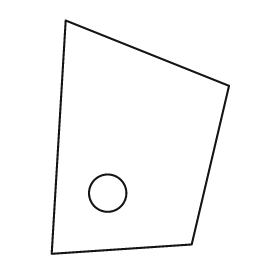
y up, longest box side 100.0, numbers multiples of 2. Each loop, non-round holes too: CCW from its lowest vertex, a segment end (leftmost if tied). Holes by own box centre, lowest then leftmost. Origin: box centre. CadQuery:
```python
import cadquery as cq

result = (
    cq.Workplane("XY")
    .moveTo(-38.0, -50.0)
    .lineTo(22.0, -46.0)
    .lineTo(38.0, 22.0)
    .lineTo(-32.0, 50.0)
    .close()
    .moveTo(-14.0, -24.0)
    .circle(8.0)
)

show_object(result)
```